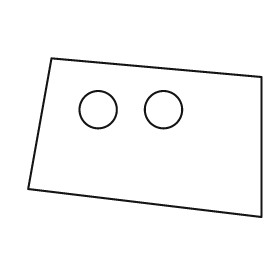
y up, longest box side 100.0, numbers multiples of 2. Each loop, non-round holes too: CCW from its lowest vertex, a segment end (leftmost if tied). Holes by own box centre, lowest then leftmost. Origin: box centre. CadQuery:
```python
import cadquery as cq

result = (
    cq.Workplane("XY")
    .moveTo(50.0, -34.0)
    .lineTo(50.0, 26.0)
    .lineTo(-40.0, 34.0)
    .lineTo(-50.0, -22.0)
    .close()
    .moveTo(-20.0, 12.0)
    .circle(8.0)
    .moveTo(8.0, 12.0)
    .circle(8.0)
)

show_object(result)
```